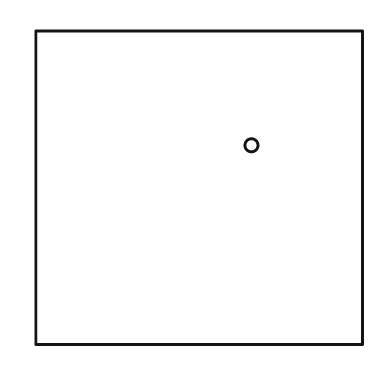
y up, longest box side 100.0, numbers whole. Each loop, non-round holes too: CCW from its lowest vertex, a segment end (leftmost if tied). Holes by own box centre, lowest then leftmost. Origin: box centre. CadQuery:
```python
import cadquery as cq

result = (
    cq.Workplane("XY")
    .moveTo(-50.0, -48.0)
    .lineTo(50.0, -48.0)
    .lineTo(50.0, 48.0)
    .lineTo(-50.0, 48.0)
    .close()
    .moveTo(16.0, 13.0)
    .circle(2.0)
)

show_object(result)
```